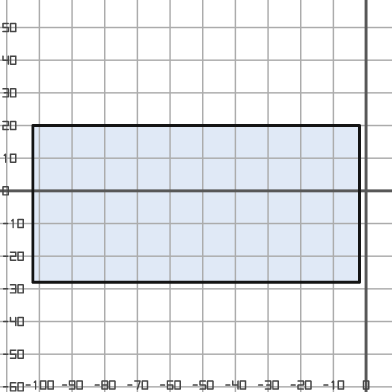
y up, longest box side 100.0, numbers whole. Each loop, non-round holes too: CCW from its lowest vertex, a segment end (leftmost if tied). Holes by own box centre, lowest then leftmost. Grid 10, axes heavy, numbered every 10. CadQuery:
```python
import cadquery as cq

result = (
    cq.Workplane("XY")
    .moveTo(-102.0, -28.0)
    .lineTo(-2.0, -28.0)
    .lineTo(-2.0, 20.0)
    .lineTo(-102.0, 20.0)
    .close()
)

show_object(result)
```